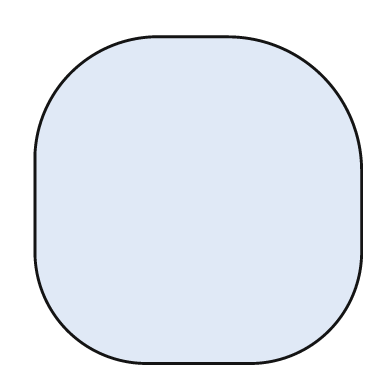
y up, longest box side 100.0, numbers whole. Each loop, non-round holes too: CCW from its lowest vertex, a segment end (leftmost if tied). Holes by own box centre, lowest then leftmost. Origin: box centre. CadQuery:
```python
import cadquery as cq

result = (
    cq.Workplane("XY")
    .moveTo(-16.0, -50.0)
    .lineTo(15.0, -50.0)
    .threePointArc((40.0, -40.0), (50.0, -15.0))
    .lineTo(50.0, 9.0)
    .threePointArc((38.0, 38.0), (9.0, 50.0))
    .lineTo(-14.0, 50.0)
    .threePointArc((-39.0, 39.0), (-50.0, 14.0))
    .lineTo(-50.0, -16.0)
    .threePointArc((-40.0, -40.0), (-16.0, -50.0))
    .close()
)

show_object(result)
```